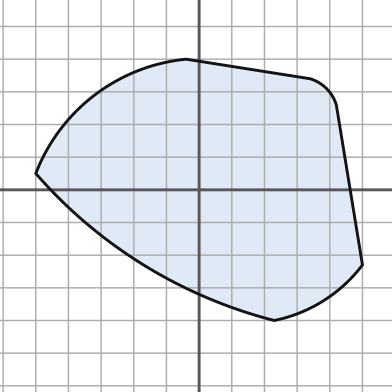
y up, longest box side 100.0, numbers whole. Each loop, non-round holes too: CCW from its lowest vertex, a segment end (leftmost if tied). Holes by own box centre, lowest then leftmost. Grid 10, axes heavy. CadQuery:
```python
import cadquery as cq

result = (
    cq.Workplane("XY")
    .moveTo(23.0, -40.0)
    .threePointArc((38.0, -34.0), (50.0, -23.0))
    .lineTo(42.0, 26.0)
    .threePointArc((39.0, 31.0), (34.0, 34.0))
    .lineTo(-4.0, 40.0)
    .threePointArc((-32.0, 29.0), (-50.0, 5.0))
    .threePointArc((-17.0, -23.0), (23.0, -40.0))
    .close()
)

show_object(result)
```